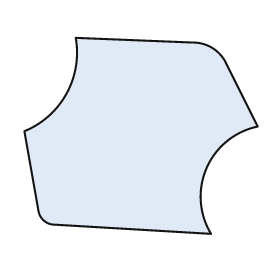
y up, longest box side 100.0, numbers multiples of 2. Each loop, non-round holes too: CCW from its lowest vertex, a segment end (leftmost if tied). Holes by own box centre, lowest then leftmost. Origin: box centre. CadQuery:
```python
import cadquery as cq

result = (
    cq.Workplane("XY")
    .moveTo(30.0, -42.0)
    .threePointArc((28.0, -14.0), (50.0, 4.0))
    .lineTo(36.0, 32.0)
    .threePointArc((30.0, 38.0), (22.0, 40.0))
    .lineTo(-28.0, 42.0)
    .threePointArc((-32.0, 18.0), (-50.0, 2.0))
    .lineTo(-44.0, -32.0)
    .threePointArc((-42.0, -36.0), (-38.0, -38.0))
    .close()
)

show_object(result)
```